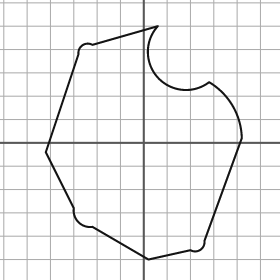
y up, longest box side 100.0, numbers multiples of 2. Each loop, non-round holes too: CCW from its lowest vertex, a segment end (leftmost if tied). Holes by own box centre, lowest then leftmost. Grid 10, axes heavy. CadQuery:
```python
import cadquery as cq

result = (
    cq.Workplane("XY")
    .moveTo(2.0, -50.0)
    .lineTo(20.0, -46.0)
    .threePointArc((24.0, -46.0), (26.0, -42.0))
    .lineTo(42.0, 2.0)
    .threePointArc((38.0, 16.0), (28.0, 26.0))
    .threePointArc((6.0, 28.0), (6.0, 50.0))
    .lineTo(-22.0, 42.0)
    .threePointArc((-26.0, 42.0), (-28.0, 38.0))
    .lineTo(-42.0, -4.0)
    .lineTo(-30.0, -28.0)
    .threePointArc((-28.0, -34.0), (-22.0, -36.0))
    .close()
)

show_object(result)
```